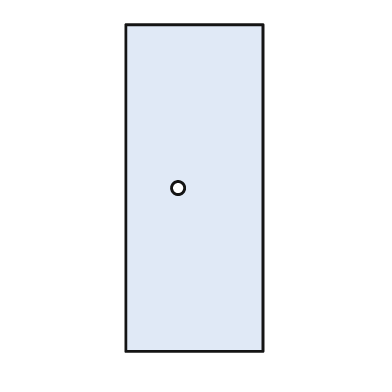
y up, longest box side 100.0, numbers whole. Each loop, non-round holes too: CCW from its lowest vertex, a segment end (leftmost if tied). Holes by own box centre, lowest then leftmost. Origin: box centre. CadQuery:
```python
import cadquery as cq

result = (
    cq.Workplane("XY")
    .moveTo(-21.0, -50.0)
    .lineTo(21.0, -50.0)
    .lineTo(21.0, 50.0)
    .lineTo(-21.0, 50.0)
    .close()
    .moveTo(-5.0, 0.0)
    .circle(2.0)
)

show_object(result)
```